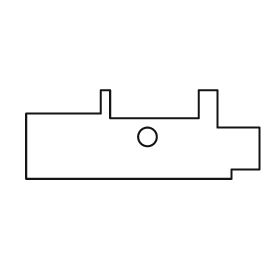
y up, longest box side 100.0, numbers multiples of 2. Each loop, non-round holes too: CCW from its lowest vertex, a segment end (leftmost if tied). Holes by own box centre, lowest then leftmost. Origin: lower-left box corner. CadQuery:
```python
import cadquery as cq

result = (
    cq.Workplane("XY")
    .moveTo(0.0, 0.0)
    .lineTo(88.0, 0.0)
    .lineTo(88.0, 4.0)
    .lineTo(100.0, 4.0)
    .lineTo(100.0, 22.0)
    .lineTo(82.0, 22.0)
    .lineTo(82.0, 38.0)
    .lineTo(74.0, 38.0)
    .lineTo(74.0, 26.0)
    .lineTo(36.0, 26.0)
    .lineTo(36.0, 38.0)
    .lineTo(32.0, 38.0)
    .lineTo(32.0, 28.0)
    .lineTo(0.0, 28.0)
    .close()
    .moveTo(52.0, 18.0)
    .circle(4.0)
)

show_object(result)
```